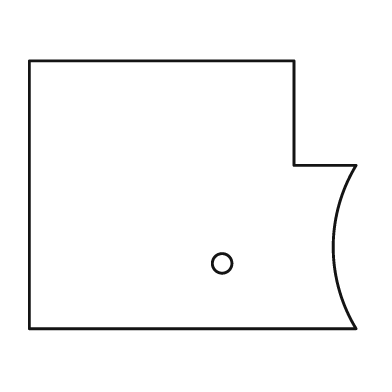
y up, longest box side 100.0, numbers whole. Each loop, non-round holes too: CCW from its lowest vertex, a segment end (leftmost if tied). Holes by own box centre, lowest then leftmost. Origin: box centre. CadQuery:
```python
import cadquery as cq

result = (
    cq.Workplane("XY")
    .moveTo(-50.0, -41.0)
    .lineTo(50.0, -41.0)
    .threePointArc((43.0, -16.0), (50.0, 9.0))
    .lineTo(31.0, 9.0)
    .lineTo(31.0, 41.0)
    .lineTo(-50.0, 41.0)
    .close()
    .moveTo(9.0, -21.0)
    .circle(3.0)
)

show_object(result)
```